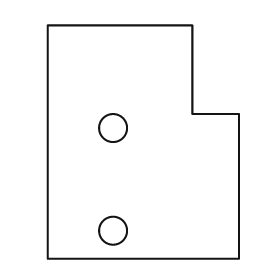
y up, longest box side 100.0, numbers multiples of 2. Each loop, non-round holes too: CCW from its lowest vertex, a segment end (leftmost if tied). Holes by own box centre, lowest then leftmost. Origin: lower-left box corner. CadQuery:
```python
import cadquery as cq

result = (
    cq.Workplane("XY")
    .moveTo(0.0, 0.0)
    .lineTo(82.0, 0.0)
    .lineTo(82.0, 62.0)
    .lineTo(62.0, 62.0)
    .lineTo(62.0, 100.0)
    .lineTo(0.0, 100.0)
    .close()
    .moveTo(28.0, 12.0)
    .circle(6.0)
    .moveTo(28.0, 56.0)
    .circle(6.0)
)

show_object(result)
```